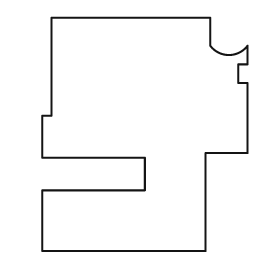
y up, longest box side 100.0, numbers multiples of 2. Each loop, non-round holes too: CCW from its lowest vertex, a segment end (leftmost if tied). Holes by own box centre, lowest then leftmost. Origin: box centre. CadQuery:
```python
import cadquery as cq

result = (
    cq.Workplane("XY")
    .moveTo(-44.0, -50.0)
    .lineTo(26.0, -50.0)
    .lineTo(26.0, -8.0)
    .lineTo(44.0, -8.0)
    .lineTo(44.0, 22.0)
    .lineTo(40.0, 22.0)
    .lineTo(40.0, 30.0)
    .lineTo(44.0, 30.0)
    .lineTo(44.0, 38.0)
    .threePointArc((36.0, 34.0), (28.0, 38.0))
    .lineTo(28.0, 50.0)
    .lineTo(-40.0, 50.0)
    .lineTo(-40.0, 8.0)
    .lineTo(-44.0, 8.0)
    .lineTo(-44.0, -10.0)
    .lineTo(0.0, -10.0)
    .lineTo(0.0, -24.0)
    .lineTo(-44.0, -24.0)
    .close()
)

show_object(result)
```